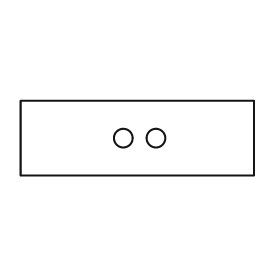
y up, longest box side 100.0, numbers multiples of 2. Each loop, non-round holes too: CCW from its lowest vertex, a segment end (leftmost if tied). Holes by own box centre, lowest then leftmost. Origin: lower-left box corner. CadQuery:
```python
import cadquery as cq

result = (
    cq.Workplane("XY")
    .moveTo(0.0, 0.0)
    .lineTo(100.0, 0.0)
    .lineTo(100.0, 32.0)
    .lineTo(0.0, 32.0)
    .close()
    .moveTo(44.0, 16.0)
    .circle(4.0)
    .moveTo(58.0, 16.0)
    .circle(4.0)
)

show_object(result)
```